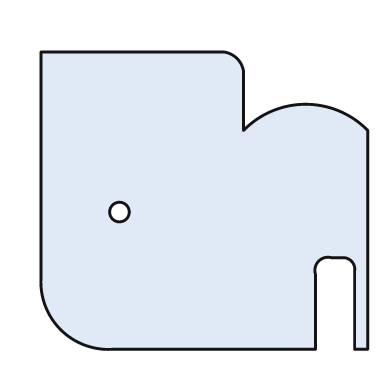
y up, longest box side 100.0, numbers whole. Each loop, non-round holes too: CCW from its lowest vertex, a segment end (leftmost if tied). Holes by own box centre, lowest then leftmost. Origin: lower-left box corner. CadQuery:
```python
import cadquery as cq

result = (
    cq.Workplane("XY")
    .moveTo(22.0, 0.0)
    .lineTo(84.0, 0.0)
    .lineTo(84.0, 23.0)
    .threePointArc((85.0, 27.0), (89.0, 28.0))
    .lineTo(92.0, 28.0)
    .threePointArc((95.0, 27.0), (96.0, 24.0))
    .lineTo(96.0, 0.0)
    .lineTo(100.0, 0.0)
    .lineTo(100.0, 67.0)
    .threePointArc((81.0, 75.0), (62.0, 67.0))
    .lineTo(62.0, 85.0)
    .threePointArc((60.0, 89.0), (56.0, 91.0))
    .lineTo(0.0, 91.0)
    .lineTo(0.0, 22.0)
    .threePointArc((6.0, 6.0), (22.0, 0.0))
    .close()
    .moveTo(24.0, 42.0)
    .circle(3.0)
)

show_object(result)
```